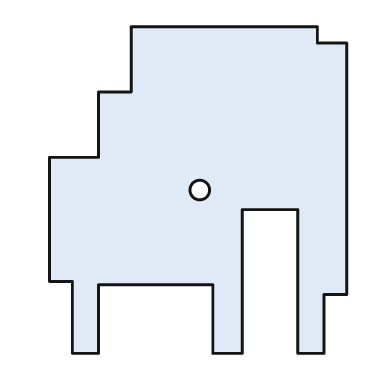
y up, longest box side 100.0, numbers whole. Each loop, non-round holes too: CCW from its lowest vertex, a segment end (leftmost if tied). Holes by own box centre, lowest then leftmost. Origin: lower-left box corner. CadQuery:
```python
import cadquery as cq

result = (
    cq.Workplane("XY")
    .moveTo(7.0, 0.0)
    .lineTo(15.0, 0.0)
    .lineTo(15.0, 21.0)
    .lineTo(50.0, 21.0)
    .lineTo(50.0, 0.0)
    .lineTo(59.0, 0.0)
    .lineTo(59.0, 44.0)
    .lineTo(76.0, 44.0)
    .lineTo(76.0, 0.0)
    .lineTo(84.0, 0.0)
    .lineTo(84.0, 18.0)
    .lineTo(91.0, 18.0)
    .lineTo(91.0, 95.0)
    .lineTo(82.0, 95.0)
    .lineTo(82.0, 100.0)
    .lineTo(25.0, 100.0)
    .lineTo(25.0, 80.0)
    .lineTo(15.0, 80.0)
    .lineTo(15.0, 60.0)
    .lineTo(0.0, 60.0)
    .lineTo(0.0, 22.0)
    .lineTo(7.0, 22.0)
    .close()
    .moveTo(46.0, 50.0)
    .circle(3.0)
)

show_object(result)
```